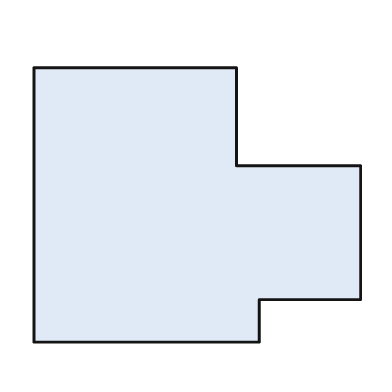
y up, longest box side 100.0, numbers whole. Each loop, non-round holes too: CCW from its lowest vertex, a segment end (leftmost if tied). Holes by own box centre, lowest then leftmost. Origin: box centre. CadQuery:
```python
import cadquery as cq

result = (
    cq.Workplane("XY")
    .moveTo(-50.0, -42.0)
    .lineTo(19.0, -42.0)
    .lineTo(19.0, -29.0)
    .lineTo(50.0, -29.0)
    .lineTo(50.0, 12.0)
    .lineTo(12.0, 12.0)
    .lineTo(12.0, 42.0)
    .lineTo(-50.0, 42.0)
    .close()
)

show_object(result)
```